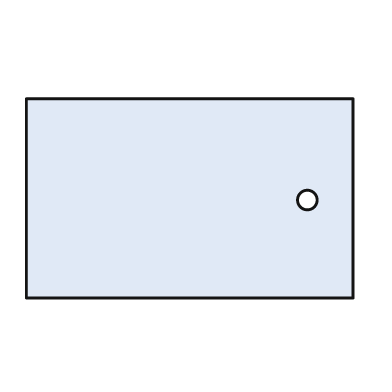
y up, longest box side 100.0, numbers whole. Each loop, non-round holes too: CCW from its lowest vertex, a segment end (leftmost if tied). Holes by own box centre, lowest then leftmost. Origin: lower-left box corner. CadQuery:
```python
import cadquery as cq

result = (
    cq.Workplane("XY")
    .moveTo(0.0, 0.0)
    .lineTo(100.0, 0.0)
    .lineTo(100.0, 61.0)
    .lineTo(0.0, 61.0)
    .close()
    .moveTo(86.0, 30.0)
    .circle(3.0)
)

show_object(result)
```